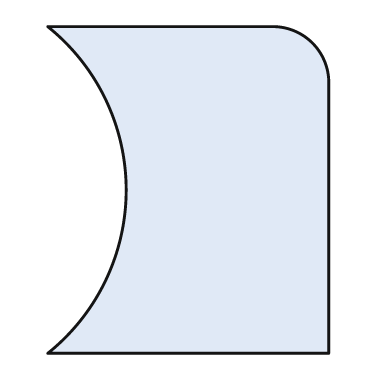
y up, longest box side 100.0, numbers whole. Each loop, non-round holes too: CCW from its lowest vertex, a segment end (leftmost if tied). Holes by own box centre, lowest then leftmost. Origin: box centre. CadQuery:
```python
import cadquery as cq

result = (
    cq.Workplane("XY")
    .moveTo(-43.0, -50.0)
    .lineTo(43.0, -50.0)
    .lineTo(43.0, 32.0)
    .threePointArc((38.0, 45.0), (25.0, 50.0))
    .lineTo(-43.0, 50.0)
    .threePointArc((-19.0, 0.0), (-43.0, -50.0))
    .close()
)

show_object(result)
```